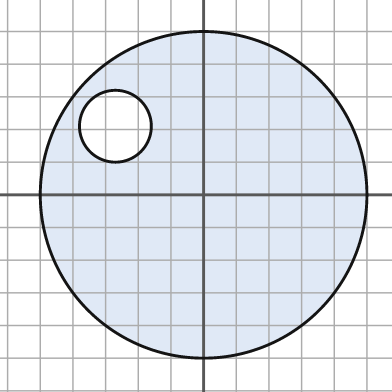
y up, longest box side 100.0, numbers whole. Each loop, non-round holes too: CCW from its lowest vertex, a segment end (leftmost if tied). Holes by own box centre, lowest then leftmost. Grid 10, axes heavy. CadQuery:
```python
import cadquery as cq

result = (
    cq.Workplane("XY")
    .moveTo(0.0, 0.0)
    .circle(50.0)
    .moveTo(-27.0, 21.0)
    .circle(11.0)
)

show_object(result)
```